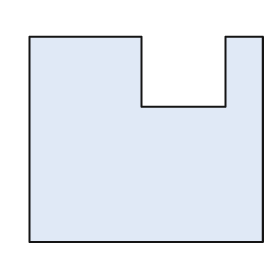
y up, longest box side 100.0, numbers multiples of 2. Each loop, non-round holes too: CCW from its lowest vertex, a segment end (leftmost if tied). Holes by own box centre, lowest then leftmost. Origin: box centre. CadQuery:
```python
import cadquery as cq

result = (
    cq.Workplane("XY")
    .moveTo(-50.0, -44.0)
    .lineTo(50.0, -44.0)
    .lineTo(50.0, 44.0)
    .lineTo(34.0, 44.0)
    .lineTo(34.0, 14.0)
    .lineTo(-2.0, 14.0)
    .lineTo(-2.0, 44.0)
    .lineTo(-50.0, 44.0)
    .close()
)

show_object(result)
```